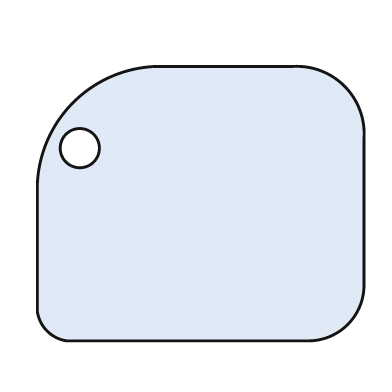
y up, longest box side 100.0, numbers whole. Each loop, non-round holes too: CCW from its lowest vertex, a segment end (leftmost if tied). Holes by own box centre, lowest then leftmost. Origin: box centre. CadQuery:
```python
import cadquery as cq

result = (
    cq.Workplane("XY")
    .moveTo(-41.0, -42.0)
    .lineTo(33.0, -42.0)
    .threePointArc((45.0, -37.0), (50.0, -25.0))
    .lineTo(50.0, 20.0)
    .threePointArc((44.0, 36.0), (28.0, 42.0))
    .lineTo(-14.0, 42.0)
    .threePointArc((-39.0, 31.0), (-50.0, 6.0))
    .lineTo(-50.0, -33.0)
    .threePointArc((-47.0, -39.0), (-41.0, -42.0))
    .close()
    .moveTo(-37.0, 17.0)
    .circle(6.0)
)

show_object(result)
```